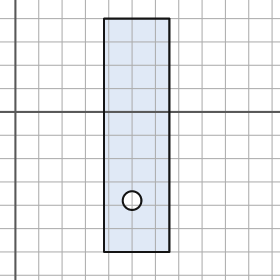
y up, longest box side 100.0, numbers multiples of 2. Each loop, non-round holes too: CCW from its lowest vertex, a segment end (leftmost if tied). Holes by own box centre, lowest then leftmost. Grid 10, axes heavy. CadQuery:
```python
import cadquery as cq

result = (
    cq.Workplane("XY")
    .moveTo(38.0, -60.0)
    .lineTo(66.0, -60.0)
    .lineTo(66.0, 40.0)
    .lineTo(38.0, 40.0)
    .close()
    .moveTo(50.0, -38.0)
    .circle(4.0)
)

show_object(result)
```